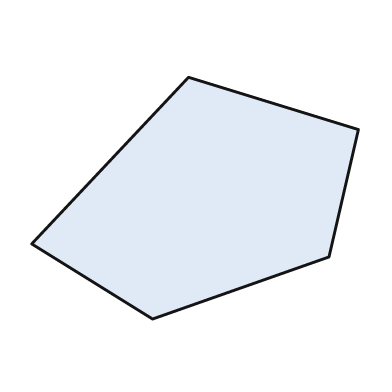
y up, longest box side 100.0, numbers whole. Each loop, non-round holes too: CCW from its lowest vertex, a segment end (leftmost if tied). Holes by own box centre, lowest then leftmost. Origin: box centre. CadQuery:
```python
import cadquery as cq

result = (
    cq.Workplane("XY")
    .moveTo(-13.0, -37.0)
    .lineTo(41.0, -18.0)
    .lineTo(50.0, 21.0)
    .lineTo(-2.0, 37.0)
    .lineTo(-50.0, -14.0)
    .close()
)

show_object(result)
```